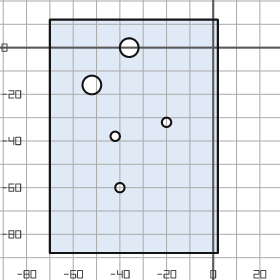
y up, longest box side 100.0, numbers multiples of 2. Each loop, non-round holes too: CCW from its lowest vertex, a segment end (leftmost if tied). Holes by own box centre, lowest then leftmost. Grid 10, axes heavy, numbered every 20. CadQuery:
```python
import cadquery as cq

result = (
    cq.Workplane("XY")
    .moveTo(-70.0, -88.0)
    .lineTo(2.0, -88.0)
    .lineTo(2.0, 12.0)
    .lineTo(-70.0, 12.0)
    .close()
    .moveTo(-40.0, -60.0)
    .circle(2.0)
    .moveTo(-42.0, -38.0)
    .circle(2.0)
    .moveTo(-20.0, -32.0)
    .circle(2.0)
    .moveTo(-52.0, -16.0)
    .circle(4.0)
    .moveTo(-36.0, 0.0)
    .circle(4.0)
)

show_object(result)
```